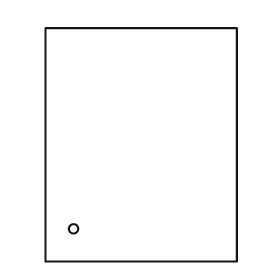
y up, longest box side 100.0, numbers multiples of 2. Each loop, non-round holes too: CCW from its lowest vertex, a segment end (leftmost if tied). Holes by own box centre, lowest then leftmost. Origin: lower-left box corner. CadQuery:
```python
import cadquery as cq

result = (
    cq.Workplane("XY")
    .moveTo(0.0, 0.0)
    .lineTo(82.0, 0.0)
    .lineTo(82.0, 100.0)
    .lineTo(0.0, 100.0)
    .close()
    .moveTo(12.0, 14.0)
    .circle(2.0)
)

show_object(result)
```